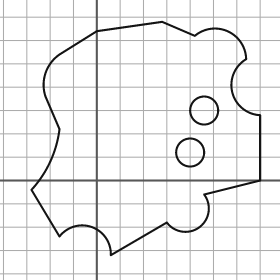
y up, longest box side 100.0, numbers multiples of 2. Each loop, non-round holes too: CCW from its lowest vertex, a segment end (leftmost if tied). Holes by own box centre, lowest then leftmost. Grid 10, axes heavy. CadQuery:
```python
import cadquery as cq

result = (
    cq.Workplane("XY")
    .moveTo(6.0, -32.0)
    .lineTo(30.0, -18.0)
    .threePointArc((44.0, -20.0), (46.0, -6.0))
    .lineTo(70.0, 0.0)
    .lineTo(70.0, 28.0)
    .threePointArc((58.0, 38.0), (64.0, 52.0))
    .threePointArc((56.0, 64.0), (42.0, 62.0))
    .lineTo(28.0, 68.0)
    .lineTo(0.0, 64.0)
    .lineTo(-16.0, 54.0)
    .threePointArc((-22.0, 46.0), (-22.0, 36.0))
    .lineTo(-16.0, 22.0)
    .threePointArc((-20.0, 8.0), (-28.0, -4.0))
    .lineTo(-16.0, -24.0)
    .threePointArc((-2.0, -20.0), (6.0, -32.0))
    .close()
    .moveTo(40.0, 12.0)
    .circle(6.0)
    .moveTo(46.0, 30.0)
    .circle(6.0)
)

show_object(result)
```